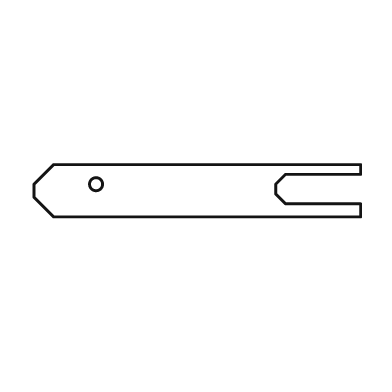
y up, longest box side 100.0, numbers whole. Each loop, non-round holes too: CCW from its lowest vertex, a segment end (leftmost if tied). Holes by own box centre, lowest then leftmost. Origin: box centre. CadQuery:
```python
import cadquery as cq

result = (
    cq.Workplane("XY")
    .moveTo(-44.0, -8.0)
    .lineTo(50.0, -8.0)
    .lineTo(50.0, -4.0)
    .lineTo(27.0, -4.0)
    .lineTo(24.0, -1.0)
    .lineTo(24.0, 2.0)
    .lineTo(27.0, 5.0)
    .lineTo(50.0, 5.0)
    .lineTo(50.0, 8.0)
    .lineTo(-44.0, 8.0)
    .lineTo(-50.0, 2.0)
    .lineTo(-50.0, -2.0)
    .close()
    .moveTo(-31.0, 2.0)
    .circle(2.0)
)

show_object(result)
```